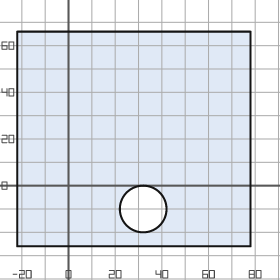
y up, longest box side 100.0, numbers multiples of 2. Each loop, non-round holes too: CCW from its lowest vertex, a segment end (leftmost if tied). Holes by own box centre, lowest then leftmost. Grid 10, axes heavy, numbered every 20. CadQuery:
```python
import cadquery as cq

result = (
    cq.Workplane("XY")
    .moveTo(-22.0, -26.0)
    .lineTo(78.0, -26.0)
    .lineTo(78.0, 66.0)
    .lineTo(-22.0, 66.0)
    .close()
    .moveTo(32.0, -10.0)
    .circle(10.0)
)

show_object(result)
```